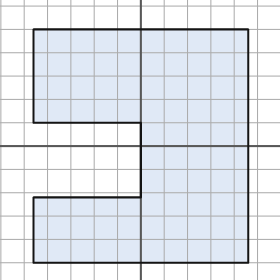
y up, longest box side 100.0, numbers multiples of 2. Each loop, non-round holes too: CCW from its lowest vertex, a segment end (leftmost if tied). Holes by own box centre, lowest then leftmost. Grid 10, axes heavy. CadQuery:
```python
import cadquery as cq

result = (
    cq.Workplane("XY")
    .moveTo(-46.0, -50.0)
    .lineTo(46.0, -50.0)
    .lineTo(46.0, 50.0)
    .lineTo(-46.0, 50.0)
    .lineTo(-46.0, 10.0)
    .lineTo(0.0, 10.0)
    .lineTo(0.0, -22.0)
    .lineTo(-46.0, -22.0)
    .close()
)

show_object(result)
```